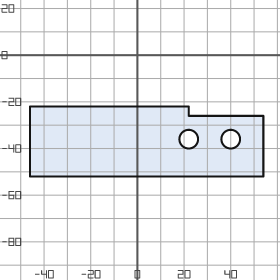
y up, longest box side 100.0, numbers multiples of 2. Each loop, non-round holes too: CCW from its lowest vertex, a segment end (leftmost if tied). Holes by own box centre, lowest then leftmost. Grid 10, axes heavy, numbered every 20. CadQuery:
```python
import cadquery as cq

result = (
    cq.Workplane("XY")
    .moveTo(-46.0, -52.0)
    .lineTo(54.0, -52.0)
    .lineTo(54.0, -26.0)
    .lineTo(22.0, -26.0)
    .lineTo(22.0, -22.0)
    .lineTo(-46.0, -22.0)
    .close()
    .moveTo(22.0, -36.0)
    .circle(4.0)
    .moveTo(40.0, -36.0)
    .circle(4.0)
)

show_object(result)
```